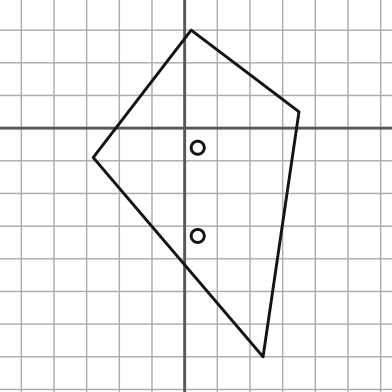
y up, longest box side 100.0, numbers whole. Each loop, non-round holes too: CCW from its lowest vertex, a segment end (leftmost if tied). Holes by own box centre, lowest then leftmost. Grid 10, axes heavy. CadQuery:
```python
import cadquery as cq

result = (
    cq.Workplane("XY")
    .moveTo(24.0, -70.0)
    .lineTo(35.0, 5.0)
    .lineTo(2.0, 30.0)
    .lineTo(-28.0, -9.0)
    .close()
    .moveTo(4.0, -33.0)
    .circle(2.0)
    .moveTo(4.0, -6.0)
    .circle(2.0)
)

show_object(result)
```